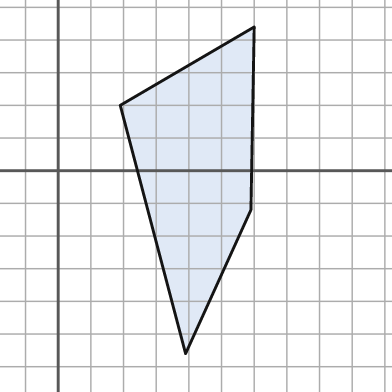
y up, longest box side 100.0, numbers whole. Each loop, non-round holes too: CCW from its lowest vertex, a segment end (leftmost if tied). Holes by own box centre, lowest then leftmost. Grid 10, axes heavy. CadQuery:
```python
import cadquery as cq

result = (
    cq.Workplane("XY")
    .moveTo(39.0, -56.0)
    .lineTo(59.0, -12.0)
    .lineTo(60.0, 44.0)
    .lineTo(19.0, 20.0)
    .close()
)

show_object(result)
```